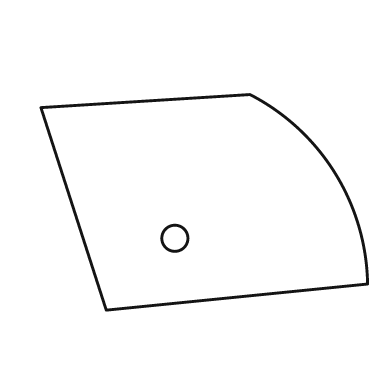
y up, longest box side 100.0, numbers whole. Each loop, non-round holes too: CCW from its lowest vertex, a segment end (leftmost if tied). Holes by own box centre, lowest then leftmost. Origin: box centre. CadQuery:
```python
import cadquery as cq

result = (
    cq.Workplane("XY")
    .moveTo(-30.0, -33.0)
    .lineTo(50.0, -25.0)
    .threePointArc((40.0, 9.0), (14.0, 33.0))
    .lineTo(-50.0, 29.0)
    .close()
    .moveTo(-9.0, -11.0)
    .circle(4.0)
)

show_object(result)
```